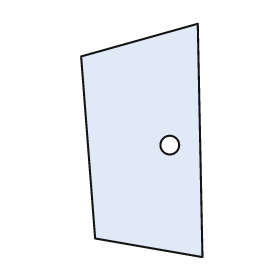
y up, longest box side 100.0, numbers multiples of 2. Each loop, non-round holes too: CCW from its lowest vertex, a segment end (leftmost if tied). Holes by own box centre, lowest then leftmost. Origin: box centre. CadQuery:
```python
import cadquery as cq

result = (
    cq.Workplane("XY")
    .moveTo(26.0, -50.0)
    .lineTo(24.0, 50.0)
    .lineTo(-26.0, 36.0)
    .lineTo(-20.0, -42.0)
    .close()
    .moveTo(12.0, -2.0)
    .circle(4.0)
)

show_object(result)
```